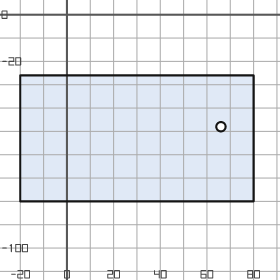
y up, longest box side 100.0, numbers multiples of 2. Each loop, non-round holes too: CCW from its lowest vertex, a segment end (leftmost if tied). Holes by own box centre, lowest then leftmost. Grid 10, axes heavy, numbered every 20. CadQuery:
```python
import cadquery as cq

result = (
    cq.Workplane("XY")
    .moveTo(-20.0, -80.0)
    .lineTo(80.0, -80.0)
    .lineTo(80.0, -26.0)
    .lineTo(-20.0, -26.0)
    .close()
    .moveTo(66.0, -48.0)
    .circle(2.0)
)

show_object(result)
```